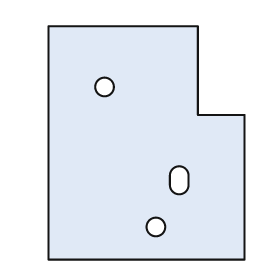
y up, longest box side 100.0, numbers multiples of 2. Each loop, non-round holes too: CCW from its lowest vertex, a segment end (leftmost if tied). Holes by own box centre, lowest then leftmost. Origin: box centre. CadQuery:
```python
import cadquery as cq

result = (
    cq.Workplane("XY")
    .moveTo(-42.0, -50.0)
    .lineTo(42.0, -50.0)
    .lineTo(42.0, 12.0)
    .lineTo(22.0, 12.0)
    .lineTo(22.0, 50.0)
    .lineTo(-42.0, 50.0)
    .close()
    .moveTo(4.0, -36.0)
    .circle(4.0)
    .moveTo(10.0, -18.0)
    .threePointArc((14.0, -22.0), (18.0, -18.0))
    .lineTo(18.0, -14.0)
    .threePointArc((14.0, -10.0), (10.0, -14.0))
    .close()
    .moveTo(-18.0, 24.0)
    .circle(4.0)
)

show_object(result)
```